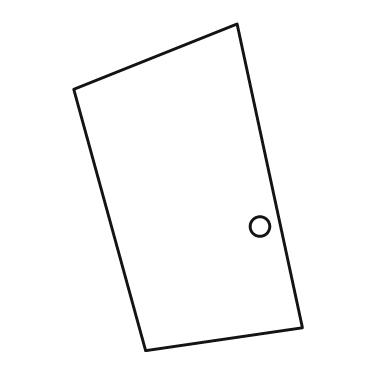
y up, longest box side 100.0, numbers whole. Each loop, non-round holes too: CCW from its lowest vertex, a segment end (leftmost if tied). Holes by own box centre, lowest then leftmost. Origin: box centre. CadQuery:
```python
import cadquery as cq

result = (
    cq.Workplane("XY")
    .moveTo(-13.0, -50.0)
    .lineTo(35.0, -43.0)
    .lineTo(15.0, 50.0)
    .lineTo(-35.0, 30.0)
    .close()
    .moveTo(22.0, -12.0)
    .circle(3.0)
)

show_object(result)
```